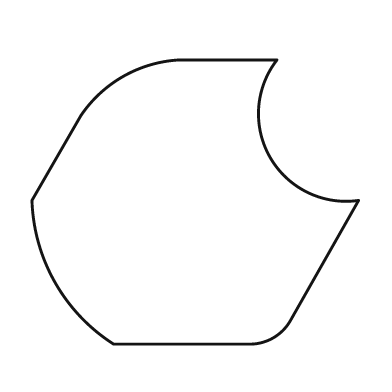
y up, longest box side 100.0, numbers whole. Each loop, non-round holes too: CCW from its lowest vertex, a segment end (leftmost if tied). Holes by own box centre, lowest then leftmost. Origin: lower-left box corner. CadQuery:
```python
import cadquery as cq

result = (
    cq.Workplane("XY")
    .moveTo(25.0, 0.0)
    .lineTo(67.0, 0.0)
    .threePointArc((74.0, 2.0), (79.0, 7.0))
    .lineTo(100.0, 44.0)
    .threePointArc((73.0, 57.0), (75.0, 87.0))
    .lineTo(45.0, 87.0)
    .threePointArc((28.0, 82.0), (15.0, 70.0))
    .lineTo(0.0, 44.0)
    .threePointArc((7.0, 19.0), (25.0, 0.0))
    .close()
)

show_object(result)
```